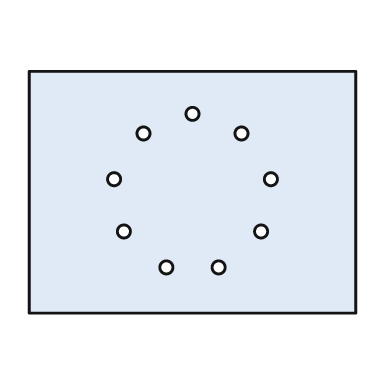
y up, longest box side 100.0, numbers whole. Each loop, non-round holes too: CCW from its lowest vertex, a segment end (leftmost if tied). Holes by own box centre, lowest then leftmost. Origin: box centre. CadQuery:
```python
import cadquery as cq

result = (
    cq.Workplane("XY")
    .moveTo(-50.0, -37.0)
    .lineTo(50.0, -37.0)
    .lineTo(50.0, 37.0)
    .lineTo(-50.0, 37.0)
    .close()
    .moveTo(-8.0, -23.0)
    .circle(2.0)
    .moveTo(8.0, -23.0)
    .circle(2.0)
    .moveTo(-21.0, -12.0)
    .circle(2.0)
    .moveTo(21.0, -12.0)
    .circle(2.0)
    .moveTo(-24.0, 4.0)
    .circle(2.0)
    .moveTo(24.0, 4.0)
    .circle(2.0)
    .moveTo(-15.0, 18.0)
    .circle(2.0)
    .moveTo(15.0, 18.0)
    .circle(2.0)
    .moveTo(0.0, 24.0)
    .circle(2.0)
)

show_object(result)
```